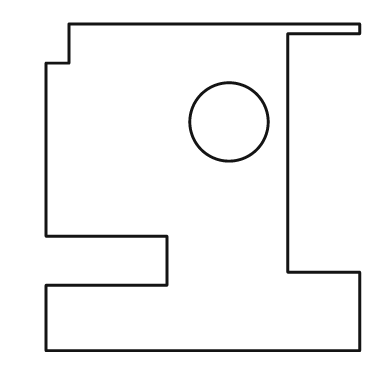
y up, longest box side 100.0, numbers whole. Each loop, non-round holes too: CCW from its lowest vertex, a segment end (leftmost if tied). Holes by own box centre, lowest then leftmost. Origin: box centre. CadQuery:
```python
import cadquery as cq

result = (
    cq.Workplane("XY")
    .moveTo(-48.0, -50.0)
    .lineTo(48.0, -50.0)
    .lineTo(48.0, -26.0)
    .lineTo(26.0, -26.0)
    .lineTo(26.0, 47.0)
    .lineTo(48.0, 47.0)
    .lineTo(48.0, 50.0)
    .lineTo(-41.0, 50.0)
    .lineTo(-41.0, 38.0)
    .lineTo(-48.0, 38.0)
    .lineTo(-48.0, -15.0)
    .lineTo(-11.0, -15.0)
    .lineTo(-11.0, -30.0)
    .lineTo(-48.0, -30.0)
    .close()
    .moveTo(8.0, 20.0)
    .circle(12.0)
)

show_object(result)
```